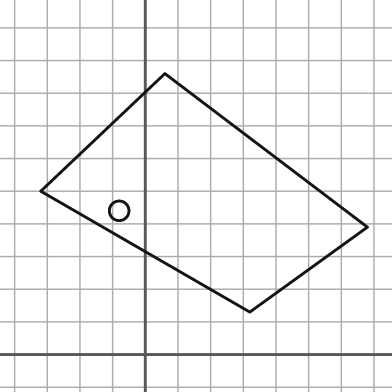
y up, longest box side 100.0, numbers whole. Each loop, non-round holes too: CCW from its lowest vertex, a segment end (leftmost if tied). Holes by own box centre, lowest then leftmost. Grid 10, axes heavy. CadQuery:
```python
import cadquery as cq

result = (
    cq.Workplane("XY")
    .moveTo(32.0, 13.0)
    .lineTo(68.0, 39.0)
    .lineTo(6.0, 86.0)
    .lineTo(-32.0, 50.0)
    .close()
    .moveTo(-8.0, 44.0)
    .circle(3.0)
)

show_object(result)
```